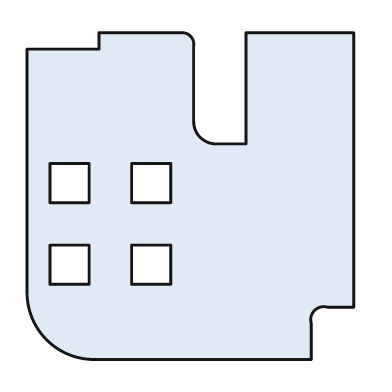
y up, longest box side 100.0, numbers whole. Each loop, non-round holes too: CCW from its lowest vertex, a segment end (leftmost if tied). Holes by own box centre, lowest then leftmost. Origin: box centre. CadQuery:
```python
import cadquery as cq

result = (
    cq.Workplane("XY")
    .moveTo(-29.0, -50.0)
    .lineTo(37.0, -50.0)
    .lineTo(37.0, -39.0)
    .threePointArc((38.0, -35.0), (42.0, -34.0))
    .lineTo(50.0, -34.0)
    .lineTo(50.0, 50.0)
    .lineTo(17.0, 50.0)
    .lineTo(17.0, 16.0)
    .lineTo(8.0, 16.0)
    .threePointArc((3.0, 18.0), (1.0, 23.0))
    .lineTo(1.0, 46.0)
    .threePointArc((0.0, 49.0), (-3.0, 50.0))
    .lineTo(-28.0, 50.0)
    .lineTo(-28.0, 45.0)
    .lineTo(-50.0, 45.0)
    .lineTo(-50.0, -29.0)
    .threePointArc((-44.0, -44.0), (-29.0, -50.0))
    .close()
    .moveTo(-43.0, -27.0)
    .lineTo(-31.0, -27.0)
    .lineTo(-31.0, -15.0)
    .lineTo(-43.0, -15.0)
    .close()
    .moveTo(-18.0, -27.0)
    .lineTo(-6.0, -27.0)
    .lineTo(-6.0, -15.0)
    .lineTo(-18.0, -15.0)
    .close()
    .moveTo(-43.0, -2.0)
    .lineTo(-31.0, -2.0)
    .lineTo(-31.0, 10.0)
    .lineTo(-43.0, 10.0)
    .close()
    .moveTo(-18.0, -2.0)
    .lineTo(-6.0, -2.0)
    .lineTo(-6.0, 10.0)
    .lineTo(-18.0, 10.0)
    .close()
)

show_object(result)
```